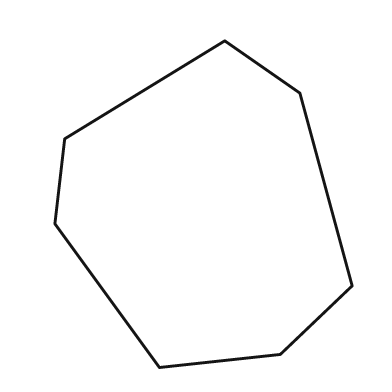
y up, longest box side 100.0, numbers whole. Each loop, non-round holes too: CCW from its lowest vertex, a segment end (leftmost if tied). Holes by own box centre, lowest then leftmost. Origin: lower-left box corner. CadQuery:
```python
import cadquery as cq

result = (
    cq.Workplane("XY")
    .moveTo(32.0, 0.0)
    .lineTo(69.0, 4.0)
    .lineTo(91.0, 25.0)
    .lineTo(75.0, 84.0)
    .lineTo(52.0, 100.0)
    .lineTo(3.0, 70.0)
    .lineTo(0.0, 44.0)
    .close()
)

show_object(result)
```